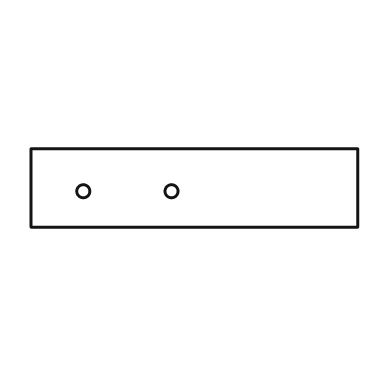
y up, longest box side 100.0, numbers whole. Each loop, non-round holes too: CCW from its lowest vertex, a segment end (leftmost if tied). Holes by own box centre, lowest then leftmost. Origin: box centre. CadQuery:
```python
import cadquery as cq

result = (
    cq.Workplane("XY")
    .moveTo(-50.0, -12.0)
    .lineTo(50.0, -12.0)
    .lineTo(50.0, 12.0)
    .lineTo(-50.0, 12.0)
    .close()
    .moveTo(-34.0, -1.0)
    .circle(2.0)
    .moveTo(-7.0, -1.0)
    .circle(2.0)
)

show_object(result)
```